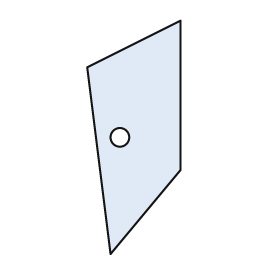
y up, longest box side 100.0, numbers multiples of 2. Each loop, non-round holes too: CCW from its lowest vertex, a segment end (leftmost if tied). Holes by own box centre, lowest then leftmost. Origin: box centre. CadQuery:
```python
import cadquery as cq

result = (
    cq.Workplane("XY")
    .moveTo(-10.0, -50.0)
    .lineTo(20.0, -14.0)
    .lineTo(20.0, 50.0)
    .lineTo(-20.0, 30.0)
    .close()
    .moveTo(-6.0, 0.0)
    .circle(4.0)
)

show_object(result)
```